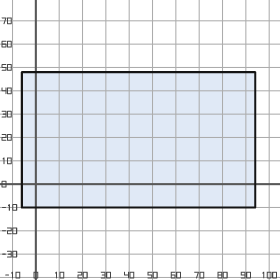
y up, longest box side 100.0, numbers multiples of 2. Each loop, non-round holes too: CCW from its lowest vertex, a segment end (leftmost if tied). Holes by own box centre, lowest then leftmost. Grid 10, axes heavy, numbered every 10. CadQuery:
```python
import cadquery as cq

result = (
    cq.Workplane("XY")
    .moveTo(-6.0, -10.0)
    .lineTo(94.0, -10.0)
    .lineTo(94.0, 48.0)
    .lineTo(-6.0, 48.0)
    .close()
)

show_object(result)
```